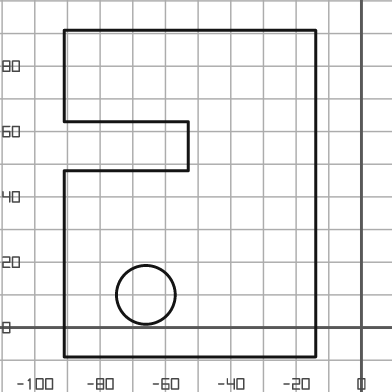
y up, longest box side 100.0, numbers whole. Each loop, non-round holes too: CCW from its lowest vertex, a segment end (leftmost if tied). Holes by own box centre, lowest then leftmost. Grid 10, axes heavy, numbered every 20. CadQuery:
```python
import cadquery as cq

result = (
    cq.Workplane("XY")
    .moveTo(-91.0, -9.0)
    .lineTo(-14.0, -9.0)
    .lineTo(-14.0, 91.0)
    .lineTo(-91.0, 91.0)
    .lineTo(-91.0, 63.0)
    .lineTo(-53.0, 63.0)
    .lineTo(-53.0, 48.0)
    .lineTo(-91.0, 48.0)
    .close()
    .moveTo(-66.0, 10.0)
    .circle(9.0)
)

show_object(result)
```